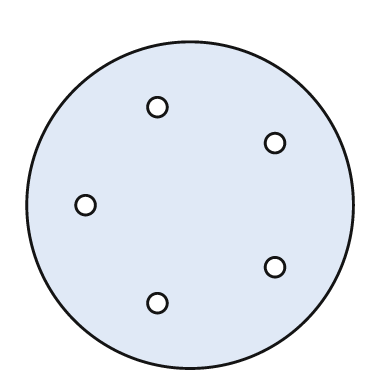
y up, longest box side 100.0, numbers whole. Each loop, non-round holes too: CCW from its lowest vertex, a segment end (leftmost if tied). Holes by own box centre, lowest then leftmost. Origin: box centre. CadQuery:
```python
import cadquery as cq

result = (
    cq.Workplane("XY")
    .moveTo(0.0, 0.0)
    .circle(50.0)
    .moveTo(-10.0, -30.0)
    .circle(3.0)
    .moveTo(26.0, -19.0)
    .circle(3.0)
    .moveTo(-32.0, 0.0)
    .circle(3.0)
    .moveTo(26.0, 19.0)
    .circle(3.0)
    .moveTo(-10.0, 30.0)
    .circle(3.0)
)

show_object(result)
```